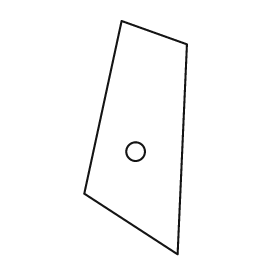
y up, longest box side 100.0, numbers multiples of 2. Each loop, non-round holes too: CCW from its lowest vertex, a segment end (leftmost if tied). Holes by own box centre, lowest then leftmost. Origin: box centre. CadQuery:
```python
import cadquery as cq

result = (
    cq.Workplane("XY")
    .moveTo(18.0, -50.0)
    .lineTo(22.0, 40.0)
    .lineTo(-6.0, 50.0)
    .lineTo(-22.0, -24.0)
    .close()
    .moveTo(0.0, -6.0)
    .circle(4.0)
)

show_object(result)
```